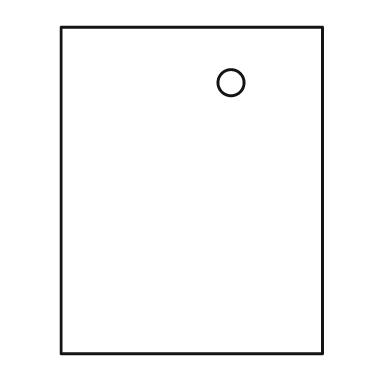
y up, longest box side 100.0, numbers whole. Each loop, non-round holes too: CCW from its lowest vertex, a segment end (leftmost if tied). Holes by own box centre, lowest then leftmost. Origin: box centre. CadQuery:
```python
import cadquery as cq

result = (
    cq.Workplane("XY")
    .moveTo(-40.0, -50.0)
    .lineTo(40.0, -50.0)
    .lineTo(40.0, 50.0)
    .lineTo(-40.0, 50.0)
    .close()
    .moveTo(12.0, 33.0)
    .circle(4.0)
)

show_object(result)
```